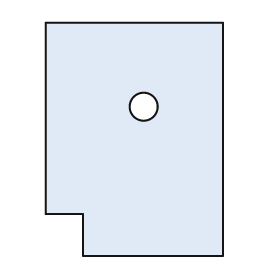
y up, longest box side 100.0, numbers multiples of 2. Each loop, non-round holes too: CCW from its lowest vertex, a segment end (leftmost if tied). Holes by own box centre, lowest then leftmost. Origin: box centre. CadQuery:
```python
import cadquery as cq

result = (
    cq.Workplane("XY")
    .moveTo(-22.0, -50.0)
    .lineTo(38.0, -50.0)
    .lineTo(38.0, 50.0)
    .lineTo(-38.0, 50.0)
    .lineTo(-38.0, -32.0)
    .lineTo(-22.0, -32.0)
    .close()
    .moveTo(4.0, 14.0)
    .circle(6.0)
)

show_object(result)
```